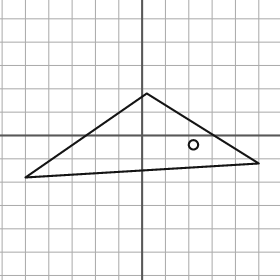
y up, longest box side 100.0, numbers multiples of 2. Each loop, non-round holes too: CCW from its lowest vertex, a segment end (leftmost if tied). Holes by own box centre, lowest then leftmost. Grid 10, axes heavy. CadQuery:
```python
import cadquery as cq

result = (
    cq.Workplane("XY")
    .moveTo(-50.0, -18.0)
    .lineTo(50.0, -12.0)
    .lineTo(2.0, 18.0)
    .close()
    .moveTo(22.0, -4.0)
    .circle(2.0)
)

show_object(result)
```